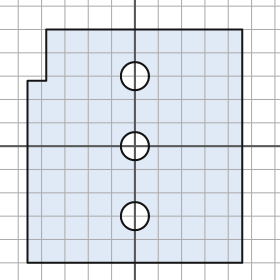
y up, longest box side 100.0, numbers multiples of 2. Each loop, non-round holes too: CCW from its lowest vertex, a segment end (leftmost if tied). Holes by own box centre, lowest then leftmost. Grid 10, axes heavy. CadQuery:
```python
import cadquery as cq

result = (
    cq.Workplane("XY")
    .moveTo(-46.0, -50.0)
    .lineTo(46.0, -50.0)
    .lineTo(46.0, 50.0)
    .lineTo(-38.0, 50.0)
    .lineTo(-38.0, 28.0)
    .lineTo(-46.0, 28.0)
    .close()
    .moveTo(0.0, -30.0)
    .circle(6.0)
    .moveTo(0.0, 0.0)
    .circle(6.0)
    .moveTo(0.0, 30.0)
    .circle(6.0)
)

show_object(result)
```